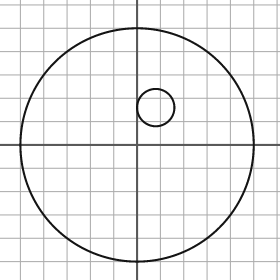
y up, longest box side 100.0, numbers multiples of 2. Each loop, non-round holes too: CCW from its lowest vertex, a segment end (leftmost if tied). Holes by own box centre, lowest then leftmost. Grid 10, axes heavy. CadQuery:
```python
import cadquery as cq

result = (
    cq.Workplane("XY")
    .moveTo(0.0, 0.0)
    .circle(50.0)
    .moveTo(8.0, 16.0)
    .circle(8.0)
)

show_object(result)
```